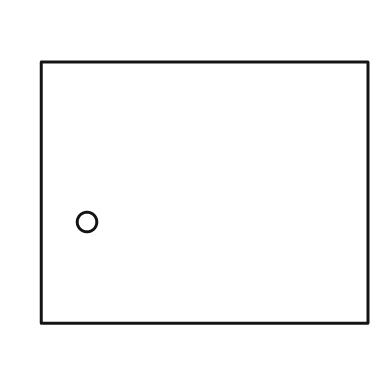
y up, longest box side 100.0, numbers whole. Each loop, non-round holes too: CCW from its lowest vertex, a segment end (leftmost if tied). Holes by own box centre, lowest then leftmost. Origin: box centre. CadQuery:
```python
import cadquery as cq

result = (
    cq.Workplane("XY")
    .moveTo(-50.0, -40.0)
    .lineTo(50.0, -40.0)
    .lineTo(50.0, 40.0)
    .lineTo(-50.0, 40.0)
    .close()
    .moveTo(-36.0, -9.0)
    .circle(3.0)
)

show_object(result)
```